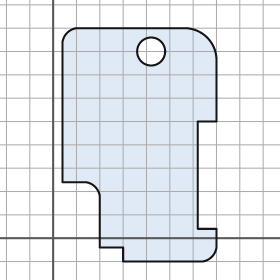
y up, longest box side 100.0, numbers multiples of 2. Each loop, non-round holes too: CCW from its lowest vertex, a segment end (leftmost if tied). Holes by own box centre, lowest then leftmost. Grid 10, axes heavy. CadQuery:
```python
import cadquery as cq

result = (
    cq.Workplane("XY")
    .moveTo(30.0, -10.0)
    .lineTo(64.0, -10.0)
    .threePointArc((68.0, -8.0), (70.0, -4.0))
    .lineTo(70.0, 4.0)
    .lineTo(62.0, 4.0)
    .lineTo(62.0, 50.0)
    .lineTo(70.0, 50.0)
    .lineTo(70.0, 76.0)
    .threePointArc((66.0, 86.0), (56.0, 90.0))
    .lineTo(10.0, 90.0)
    .threePointArc((6.0, 88.0), (4.0, 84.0))
    .lineTo(4.0, 24.0)
    .lineTo(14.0, 24.0)
    .threePointArc((18.0, 22.0), (20.0, 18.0))
    .lineTo(20.0, -4.0)
    .lineTo(30.0, -4.0)
    .close()
    .moveTo(42.0, 80.0)
    .circle(6.0)
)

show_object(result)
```